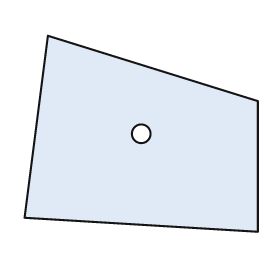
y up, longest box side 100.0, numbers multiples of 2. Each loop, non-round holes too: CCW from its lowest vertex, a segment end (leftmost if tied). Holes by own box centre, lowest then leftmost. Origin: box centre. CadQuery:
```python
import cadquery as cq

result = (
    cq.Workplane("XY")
    .moveTo(50.0, -42.0)
    .lineTo(50.0, 14.0)
    .lineTo(-40.0, 42.0)
    .lineTo(-50.0, -36.0)
    .close()
    .moveTo(0.0, 0.0)
    .circle(4.0)
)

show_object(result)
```